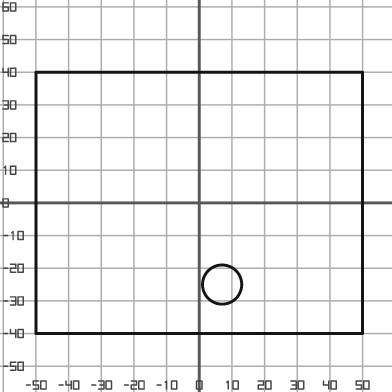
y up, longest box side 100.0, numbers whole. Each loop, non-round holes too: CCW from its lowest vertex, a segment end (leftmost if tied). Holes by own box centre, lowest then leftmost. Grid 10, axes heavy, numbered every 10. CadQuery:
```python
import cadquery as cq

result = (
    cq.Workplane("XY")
    .moveTo(-50.0, -40.0)
    .lineTo(50.0, -40.0)
    .lineTo(50.0, 40.0)
    .lineTo(-50.0, 40.0)
    .close()
    .moveTo(7.0, -25.0)
    .circle(6.0)
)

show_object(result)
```